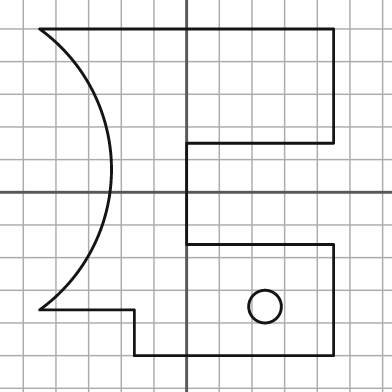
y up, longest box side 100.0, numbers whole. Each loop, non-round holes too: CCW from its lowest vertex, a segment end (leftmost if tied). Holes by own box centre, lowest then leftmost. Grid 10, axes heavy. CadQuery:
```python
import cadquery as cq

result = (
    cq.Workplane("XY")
    .moveTo(-16.0, -50.0)
    .lineTo(45.0, -50.0)
    .lineTo(45.0, -16.0)
    .lineTo(0.0, -16.0)
    .lineTo(0.0, 15.0)
    .lineTo(45.0, 15.0)
    .lineTo(45.0, 50.0)
    .lineTo(-45.0, 50.0)
    .threePointArc((-23.0, 7.0), (-45.0, -36.0))
    .lineTo(-16.0, -36.0)
    .close()
    .moveTo(24.0, -35.0)
    .circle(5.0)
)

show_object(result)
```